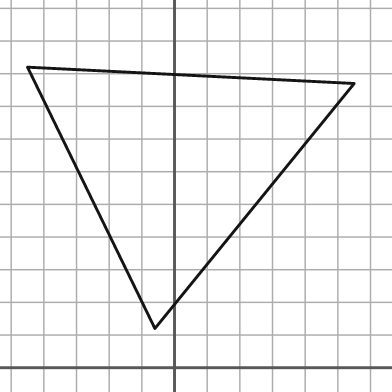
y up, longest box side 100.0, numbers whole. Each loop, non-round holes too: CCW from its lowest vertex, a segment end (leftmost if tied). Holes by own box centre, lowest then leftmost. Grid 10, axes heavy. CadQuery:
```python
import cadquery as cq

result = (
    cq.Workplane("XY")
    .moveTo(-6.0, 12.0)
    .lineTo(55.0, 87.0)
    .lineTo(-45.0, 92.0)
    .close()
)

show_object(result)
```